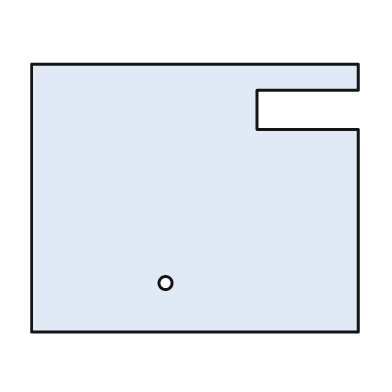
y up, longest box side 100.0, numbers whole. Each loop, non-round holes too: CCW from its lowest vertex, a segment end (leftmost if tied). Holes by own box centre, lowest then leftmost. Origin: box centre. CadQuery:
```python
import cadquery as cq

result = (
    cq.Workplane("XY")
    .moveTo(-50.0, -41.0)
    .lineTo(50.0, -41.0)
    .lineTo(50.0, 21.0)
    .lineTo(19.0, 21.0)
    .lineTo(19.0, 33.0)
    .lineTo(50.0, 33.0)
    .lineTo(50.0, 41.0)
    .lineTo(-50.0, 41.0)
    .close()
    .moveTo(-9.0, -26.0)
    .circle(2.0)
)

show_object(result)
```